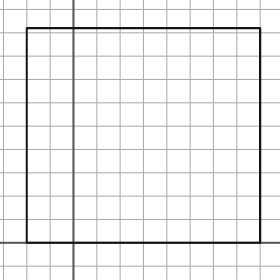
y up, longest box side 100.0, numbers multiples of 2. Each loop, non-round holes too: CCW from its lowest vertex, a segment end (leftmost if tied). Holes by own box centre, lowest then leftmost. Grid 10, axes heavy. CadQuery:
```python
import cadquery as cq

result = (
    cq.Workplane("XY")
    .moveTo(-20.0, 0.0)
    .lineTo(80.0, 0.0)
    .lineTo(80.0, 92.0)
    .lineTo(-20.0, 92.0)
    .close()
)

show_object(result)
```